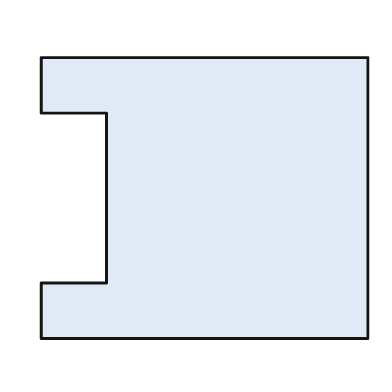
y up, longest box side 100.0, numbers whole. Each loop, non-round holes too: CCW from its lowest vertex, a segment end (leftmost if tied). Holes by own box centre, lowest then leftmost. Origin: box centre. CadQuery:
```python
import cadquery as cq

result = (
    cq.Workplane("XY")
    .moveTo(-50.0, -43.0)
    .lineTo(50.0, -43.0)
    .lineTo(50.0, 43.0)
    .lineTo(-50.0, 43.0)
    .lineTo(-50.0, 26.0)
    .lineTo(-30.0, 26.0)
    .lineTo(-30.0, -26.0)
    .lineTo(-50.0, -26.0)
    .close()
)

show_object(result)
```